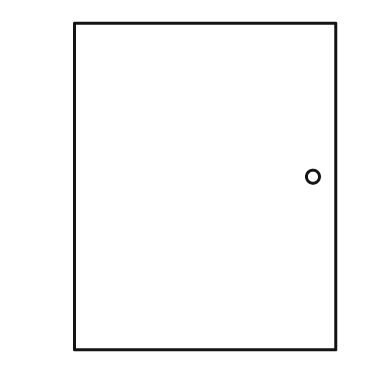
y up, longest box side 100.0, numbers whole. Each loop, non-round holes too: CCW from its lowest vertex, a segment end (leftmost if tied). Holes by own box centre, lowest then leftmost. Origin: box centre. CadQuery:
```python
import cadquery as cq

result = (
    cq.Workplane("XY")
    .moveTo(-40.0, -50.0)
    .lineTo(40.0, -50.0)
    .lineTo(40.0, 50.0)
    .lineTo(-40.0, 50.0)
    .close()
    .moveTo(33.0, 3.0)
    .circle(2.0)
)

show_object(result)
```